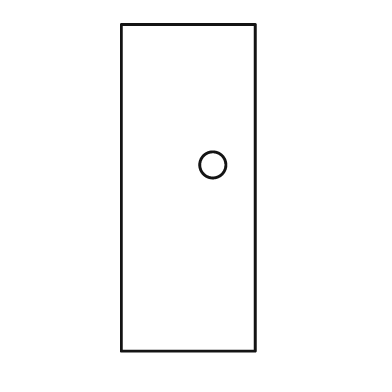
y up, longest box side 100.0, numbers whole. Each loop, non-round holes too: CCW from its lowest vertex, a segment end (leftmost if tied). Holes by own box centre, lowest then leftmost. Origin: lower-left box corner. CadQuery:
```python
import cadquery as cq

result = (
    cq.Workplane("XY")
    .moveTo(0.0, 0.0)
    .lineTo(41.0, 0.0)
    .lineTo(41.0, 100.0)
    .lineTo(0.0, 100.0)
    .close()
    .moveTo(28.0, 57.0)
    .circle(4.0)
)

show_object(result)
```